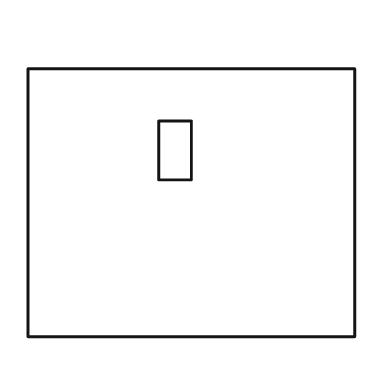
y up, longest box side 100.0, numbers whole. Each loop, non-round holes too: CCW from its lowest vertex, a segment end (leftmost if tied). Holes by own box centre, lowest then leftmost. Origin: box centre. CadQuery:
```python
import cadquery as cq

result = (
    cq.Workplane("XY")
    .moveTo(-50.0, -41.0)
    .lineTo(50.0, -41.0)
    .lineTo(50.0, 41.0)
    .lineTo(-50.0, 41.0)
    .close()
    .moveTo(-10.0, 7.0)
    .lineTo(0.0, 7.0)
    .lineTo(0.0, 25.0)
    .lineTo(-10.0, 25.0)
    .close()
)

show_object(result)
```